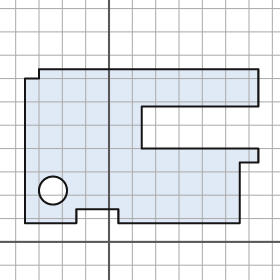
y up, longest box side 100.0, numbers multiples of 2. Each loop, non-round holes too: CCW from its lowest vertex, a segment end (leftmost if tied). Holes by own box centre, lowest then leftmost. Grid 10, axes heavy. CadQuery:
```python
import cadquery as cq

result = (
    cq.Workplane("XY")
    .moveTo(-36.0, 8.0)
    .lineTo(-14.0, 8.0)
    .lineTo(-14.0, 14.0)
    .lineTo(4.0, 14.0)
    .lineTo(4.0, 8.0)
    .lineTo(56.0, 8.0)
    .lineTo(56.0, 34.0)
    .lineTo(64.0, 34.0)
    .lineTo(64.0, 40.0)
    .lineTo(14.0, 40.0)
    .lineTo(14.0, 58.0)
    .lineTo(64.0, 58.0)
    .lineTo(64.0, 74.0)
    .lineTo(-30.0, 74.0)
    .lineTo(-30.0, 70.0)
    .lineTo(-36.0, 70.0)
    .close()
    .moveTo(-24.0, 22.0)
    .circle(6.0)
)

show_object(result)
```